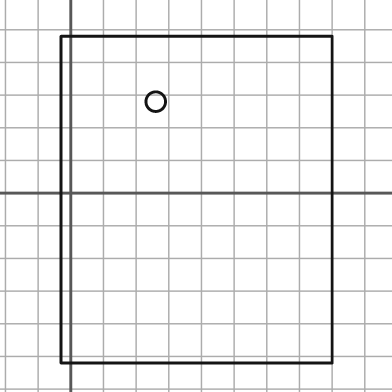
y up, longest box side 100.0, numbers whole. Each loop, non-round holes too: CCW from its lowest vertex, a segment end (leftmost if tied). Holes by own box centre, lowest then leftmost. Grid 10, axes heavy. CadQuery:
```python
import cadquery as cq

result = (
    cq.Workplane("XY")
    .moveTo(-3.0, -52.0)
    .lineTo(80.0, -52.0)
    .lineTo(80.0, 48.0)
    .lineTo(-3.0, 48.0)
    .close()
    .moveTo(26.0, 28.0)
    .circle(3.0)
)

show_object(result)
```